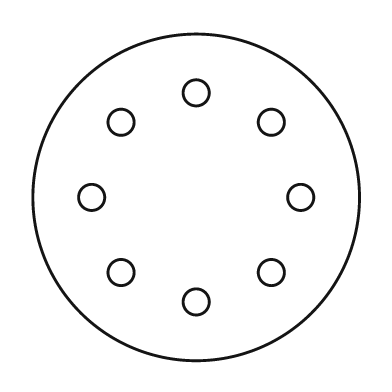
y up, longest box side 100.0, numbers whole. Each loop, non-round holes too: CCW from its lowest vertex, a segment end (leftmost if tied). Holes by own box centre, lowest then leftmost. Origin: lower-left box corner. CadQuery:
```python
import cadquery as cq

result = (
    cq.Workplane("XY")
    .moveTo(50.0, 50.0)
    .circle(50.0)
    .moveTo(50.0, 18.0)
    .circle(4.0)
    .moveTo(27.0, 27.0)
    .circle(4.0)
    .moveTo(73.0, 27.0)
    .circle(4.0)
    .moveTo(18.0, 50.0)
    .circle(4.0)
    .moveTo(82.0, 50.0)
    .circle(4.0)
    .moveTo(27.0, 73.0)
    .circle(4.0)
    .moveTo(73.0, 73.0)
    .circle(4.0)
    .moveTo(50.0, 82.0)
    .circle(4.0)
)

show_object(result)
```